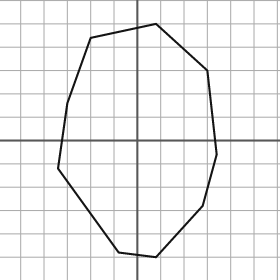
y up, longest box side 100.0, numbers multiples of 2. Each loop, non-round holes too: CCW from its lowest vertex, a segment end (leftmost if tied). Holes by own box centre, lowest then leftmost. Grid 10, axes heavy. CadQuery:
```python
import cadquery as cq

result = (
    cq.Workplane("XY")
    .moveTo(8.0, -50.0)
    .lineTo(28.0, -28.0)
    .lineTo(34.0, -6.0)
    .lineTo(30.0, 30.0)
    .lineTo(8.0, 50.0)
    .lineTo(-20.0, 44.0)
    .lineTo(-30.0, 16.0)
    .lineTo(-34.0, -12.0)
    .lineTo(-8.0, -48.0)
    .close()
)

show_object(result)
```